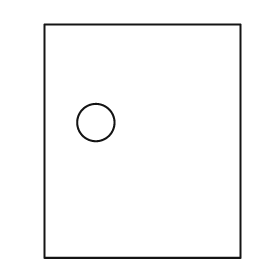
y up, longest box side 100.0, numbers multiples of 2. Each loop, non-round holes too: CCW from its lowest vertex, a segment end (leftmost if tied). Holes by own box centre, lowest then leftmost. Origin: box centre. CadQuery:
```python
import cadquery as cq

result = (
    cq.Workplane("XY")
    .moveTo(-42.0, -50.0)
    .lineTo(42.0, -50.0)
    .lineTo(42.0, 50.0)
    .lineTo(-42.0, 50.0)
    .close()
    .moveTo(-20.0, 8.0)
    .circle(8.0)
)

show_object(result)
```